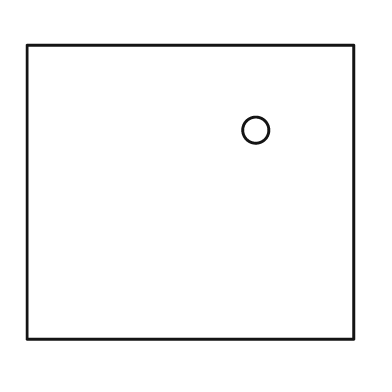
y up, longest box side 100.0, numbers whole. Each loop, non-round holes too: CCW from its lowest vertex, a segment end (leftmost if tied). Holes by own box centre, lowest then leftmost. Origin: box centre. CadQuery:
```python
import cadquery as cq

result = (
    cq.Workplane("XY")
    .moveTo(-50.0, -45.0)
    .lineTo(50.0, -45.0)
    .lineTo(50.0, 45.0)
    .lineTo(-50.0, 45.0)
    .close()
    .moveTo(20.0, 19.0)
    .circle(4.0)
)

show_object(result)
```